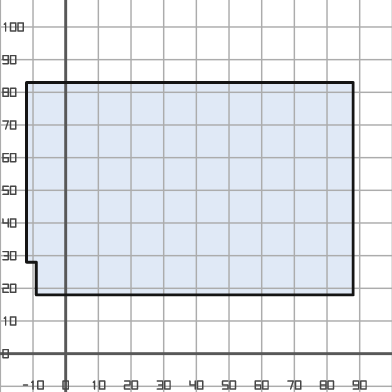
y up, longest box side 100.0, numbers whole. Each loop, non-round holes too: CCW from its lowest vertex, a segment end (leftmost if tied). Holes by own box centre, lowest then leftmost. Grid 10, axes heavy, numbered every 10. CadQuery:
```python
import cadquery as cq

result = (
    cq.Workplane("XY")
    .moveTo(-9.0, 18.0)
    .lineTo(88.0, 18.0)
    .lineTo(88.0, 83.0)
    .lineTo(-12.0, 83.0)
    .lineTo(-12.0, 28.0)
    .lineTo(-9.0, 28.0)
    .close()
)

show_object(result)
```